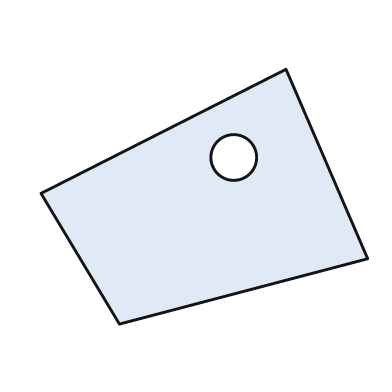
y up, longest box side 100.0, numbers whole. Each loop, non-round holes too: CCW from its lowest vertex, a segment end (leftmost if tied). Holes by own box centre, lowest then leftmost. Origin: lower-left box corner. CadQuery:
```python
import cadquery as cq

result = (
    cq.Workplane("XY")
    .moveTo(24.0, 0.0)
    .lineTo(100.0, 20.0)
    .lineTo(75.0, 78.0)
    .lineTo(0.0, 40.0)
    .close()
    .moveTo(59.0, 51.0)
    .circle(7.0)
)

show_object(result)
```